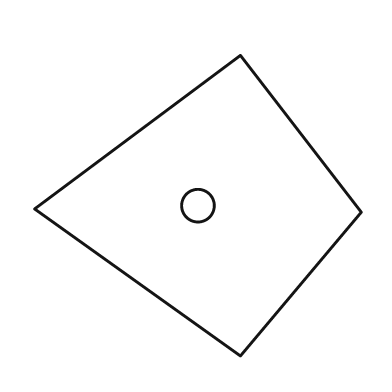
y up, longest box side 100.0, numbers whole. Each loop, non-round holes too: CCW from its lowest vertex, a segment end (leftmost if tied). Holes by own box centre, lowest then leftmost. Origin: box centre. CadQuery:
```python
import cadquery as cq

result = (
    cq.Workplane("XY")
    .moveTo(13.0, -46.0)
    .lineTo(50.0, -2.0)
    .lineTo(13.0, 46.0)
    .lineTo(-50.0, -1.0)
    .close()
    .moveTo(0.0, 0.0)
    .circle(5.0)
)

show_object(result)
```